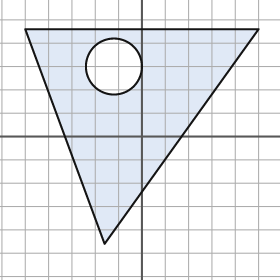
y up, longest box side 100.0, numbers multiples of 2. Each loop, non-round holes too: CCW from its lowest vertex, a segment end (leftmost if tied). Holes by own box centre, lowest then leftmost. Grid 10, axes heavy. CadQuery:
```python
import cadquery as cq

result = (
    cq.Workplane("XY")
    .moveTo(-16.0, -46.0)
    .lineTo(50.0, 46.0)
    .lineTo(-50.0, 46.0)
    .close()
    .moveTo(-12.0, 30.0)
    .circle(12.0)
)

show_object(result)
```